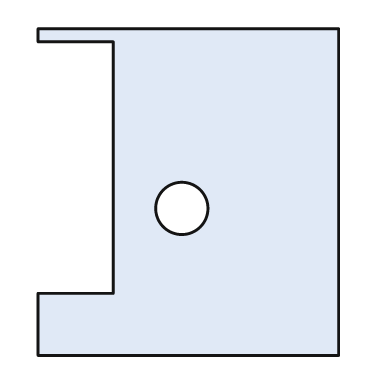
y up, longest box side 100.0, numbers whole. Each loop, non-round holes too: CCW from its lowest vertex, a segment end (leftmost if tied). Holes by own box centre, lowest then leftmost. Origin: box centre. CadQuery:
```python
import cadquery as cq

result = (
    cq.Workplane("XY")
    .moveTo(-46.0, -50.0)
    .lineTo(46.0, -50.0)
    .lineTo(46.0, 50.0)
    .lineTo(-46.0, 50.0)
    .lineTo(-46.0, 46.0)
    .lineTo(-23.0, 46.0)
    .lineTo(-23.0, -31.0)
    .lineTo(-46.0, -31.0)
    .close()
    .moveTo(-2.0, -5.0)
    .circle(8.0)
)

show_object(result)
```